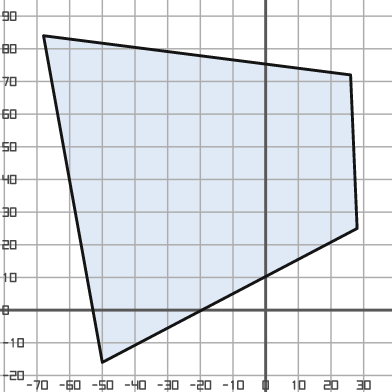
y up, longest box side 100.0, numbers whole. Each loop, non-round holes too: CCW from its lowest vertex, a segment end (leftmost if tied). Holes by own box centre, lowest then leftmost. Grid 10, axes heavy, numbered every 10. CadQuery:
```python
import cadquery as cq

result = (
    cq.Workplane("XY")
    .moveTo(-50.0, -16.0)
    .lineTo(28.0, 25.0)
    .lineTo(26.0, 72.0)
    .lineTo(-68.0, 84.0)
    .close()
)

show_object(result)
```